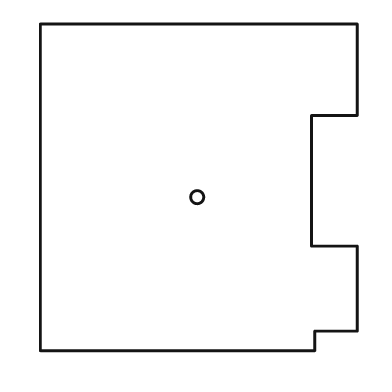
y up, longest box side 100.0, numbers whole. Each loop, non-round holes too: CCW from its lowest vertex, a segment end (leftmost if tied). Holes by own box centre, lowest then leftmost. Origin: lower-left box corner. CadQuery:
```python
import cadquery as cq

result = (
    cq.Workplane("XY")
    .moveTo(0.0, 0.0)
    .lineTo(84.0, 0.0)
    .lineTo(84.0, 6.0)
    .lineTo(97.0, 6.0)
    .lineTo(97.0, 32.0)
    .lineTo(83.0, 32.0)
    .lineTo(83.0, 72.0)
    .lineTo(97.0, 72.0)
    .lineTo(97.0, 100.0)
    .lineTo(0.0, 100.0)
    .close()
    .moveTo(48.0, 47.0)
    .circle(2.0)
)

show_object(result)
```